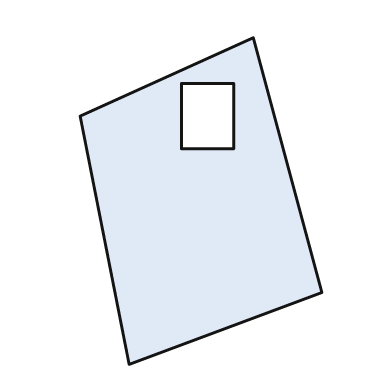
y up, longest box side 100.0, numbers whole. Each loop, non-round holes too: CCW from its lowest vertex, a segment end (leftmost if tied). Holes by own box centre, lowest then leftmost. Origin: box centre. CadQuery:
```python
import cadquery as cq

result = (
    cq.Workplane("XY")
    .moveTo(-22.0, -50.0)
    .lineTo(37.0, -28.0)
    .lineTo(16.0, 50.0)
    .lineTo(-37.0, 26.0)
    .close()
    .moveTo(-6.0, 16.0)
    .lineTo(10.0, 16.0)
    .lineTo(10.0, 36.0)
    .lineTo(-6.0, 36.0)
    .close()
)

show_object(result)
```